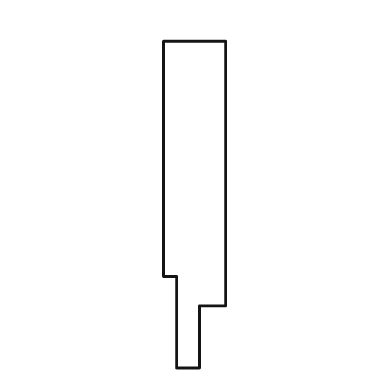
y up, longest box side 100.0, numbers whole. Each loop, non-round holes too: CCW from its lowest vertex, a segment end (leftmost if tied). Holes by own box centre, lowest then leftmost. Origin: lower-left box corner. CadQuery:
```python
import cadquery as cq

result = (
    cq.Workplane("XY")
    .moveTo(4.0, 0.0)
    .lineTo(11.0, 0.0)
    .lineTo(11.0, 19.0)
    .lineTo(19.0, 19.0)
    .lineTo(19.0, 100.0)
    .lineTo(0.0, 100.0)
    .lineTo(0.0, 28.0)
    .lineTo(4.0, 28.0)
    .close()
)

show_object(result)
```